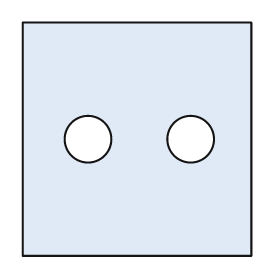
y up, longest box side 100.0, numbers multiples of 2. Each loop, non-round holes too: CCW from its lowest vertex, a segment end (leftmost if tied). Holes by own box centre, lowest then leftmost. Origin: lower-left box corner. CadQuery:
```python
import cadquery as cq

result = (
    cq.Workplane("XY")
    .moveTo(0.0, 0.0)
    .lineTo(98.0, 0.0)
    .lineTo(98.0, 100.0)
    .lineTo(0.0, 100.0)
    .close()
    .moveTo(28.0, 50.0)
    .circle(10.0)
    .moveTo(72.0, 50.0)
    .circle(10.0)
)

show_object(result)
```